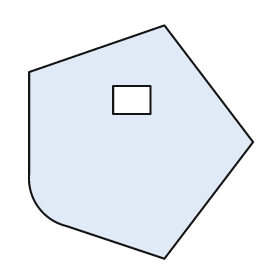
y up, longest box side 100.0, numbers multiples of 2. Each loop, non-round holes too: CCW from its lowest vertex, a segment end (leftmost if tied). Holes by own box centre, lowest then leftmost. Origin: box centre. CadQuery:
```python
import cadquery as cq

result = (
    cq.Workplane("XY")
    .moveTo(10.0, -50.0)
    .lineTo(48.0, 0.0)
    .lineTo(10.0, 50.0)
    .lineTo(-48.0, 30.0)
    .lineTo(-48.0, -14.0)
    .threePointArc((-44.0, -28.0), (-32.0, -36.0))
    .close()
    .moveTo(-12.0, 12.0)
    .lineTo(4.0, 12.0)
    .lineTo(4.0, 24.0)
    .lineTo(-12.0, 24.0)
    .close()
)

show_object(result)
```